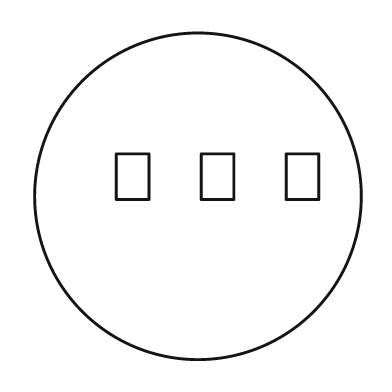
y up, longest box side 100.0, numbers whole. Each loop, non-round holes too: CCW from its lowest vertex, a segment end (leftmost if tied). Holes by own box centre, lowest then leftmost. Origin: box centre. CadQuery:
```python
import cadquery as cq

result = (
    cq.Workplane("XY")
    .moveTo(0.0, 0.0)
    .circle(50.0)
    .moveTo(-25.0, -1.0)
    .lineTo(-15.0, -1.0)
    .lineTo(-15.0, 13.0)
    .lineTo(-25.0, 13.0)
    .close()
    .moveTo(1.0, -1.0)
    .lineTo(11.0, -1.0)
    .lineTo(11.0, 13.0)
    .lineTo(1.0, 13.0)
    .close()
    .moveTo(27.0, -1.0)
    .lineTo(37.0, -1.0)
    .lineTo(37.0, 13.0)
    .lineTo(27.0, 13.0)
    .close()
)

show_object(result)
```